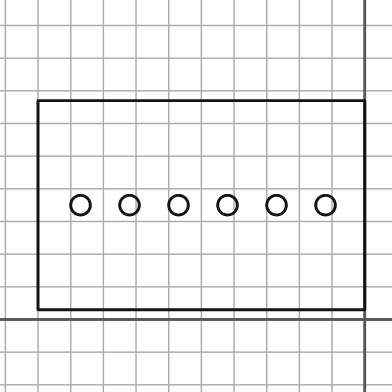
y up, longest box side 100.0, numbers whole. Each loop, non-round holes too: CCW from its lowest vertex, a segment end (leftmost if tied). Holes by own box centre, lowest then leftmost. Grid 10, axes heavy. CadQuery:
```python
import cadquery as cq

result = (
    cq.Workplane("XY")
    .moveTo(-100.0, 3.0)
    .lineTo(0.0, 3.0)
    .lineTo(0.0, 67.0)
    .lineTo(-100.0, 67.0)
    .close()
    .moveTo(-87.0, 35.0)
    .circle(3.0)
    .moveTo(-72.0, 35.0)
    .circle(3.0)
    .moveTo(-57.0, 35.0)
    .circle(3.0)
    .moveTo(-42.0, 35.0)
    .circle(3.0)
    .moveTo(-27.0, 35.0)
    .circle(3.0)
    .moveTo(-12.0, 35.0)
    .circle(3.0)
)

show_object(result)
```